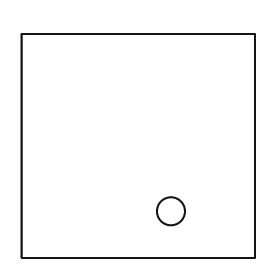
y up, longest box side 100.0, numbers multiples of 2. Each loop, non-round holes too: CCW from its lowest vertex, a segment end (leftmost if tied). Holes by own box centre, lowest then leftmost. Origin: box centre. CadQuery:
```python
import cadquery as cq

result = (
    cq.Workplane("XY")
    .moveTo(-50.0, -48.0)
    .lineTo(50.0, -48.0)
    .lineTo(50.0, 48.0)
    .lineTo(-50.0, 48.0)
    .close()
    .moveTo(14.0, -28.0)
    .circle(6.0)
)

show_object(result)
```